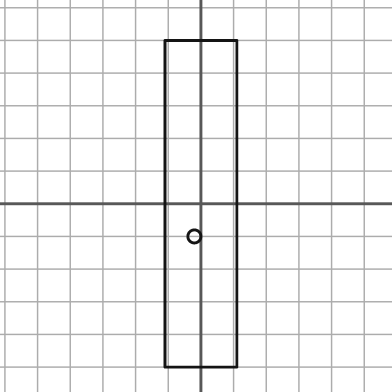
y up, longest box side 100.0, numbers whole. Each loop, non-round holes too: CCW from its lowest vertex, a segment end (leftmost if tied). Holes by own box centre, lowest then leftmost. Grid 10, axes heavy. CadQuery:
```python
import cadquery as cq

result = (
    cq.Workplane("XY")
    .moveTo(-11.0, -50.0)
    .lineTo(11.0, -50.0)
    .lineTo(11.0, 50.0)
    .lineTo(-11.0, 50.0)
    .close()
    .moveTo(-2.0, -10.0)
    .circle(2.0)
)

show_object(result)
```